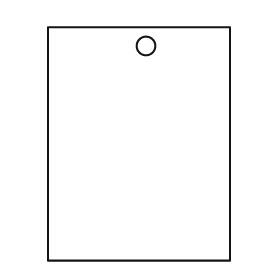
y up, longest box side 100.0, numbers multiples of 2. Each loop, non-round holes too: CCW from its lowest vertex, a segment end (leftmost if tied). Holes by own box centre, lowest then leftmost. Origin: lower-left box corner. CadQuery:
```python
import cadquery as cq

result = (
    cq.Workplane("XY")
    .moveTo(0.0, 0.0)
    .lineTo(78.0, 0.0)
    .lineTo(78.0, 100.0)
    .lineTo(0.0, 100.0)
    .close()
    .moveTo(42.0, 92.0)
    .circle(4.0)
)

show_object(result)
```